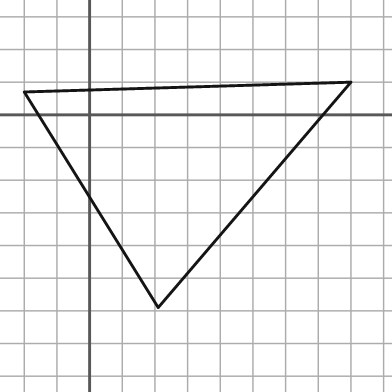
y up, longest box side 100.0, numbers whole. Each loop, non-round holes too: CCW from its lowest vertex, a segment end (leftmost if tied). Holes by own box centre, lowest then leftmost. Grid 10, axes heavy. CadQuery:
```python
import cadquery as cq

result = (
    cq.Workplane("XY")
    .moveTo(21.0, -59.0)
    .lineTo(80.0, 10.0)
    .lineTo(-20.0, 7.0)
    .close()
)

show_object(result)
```